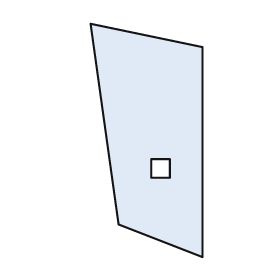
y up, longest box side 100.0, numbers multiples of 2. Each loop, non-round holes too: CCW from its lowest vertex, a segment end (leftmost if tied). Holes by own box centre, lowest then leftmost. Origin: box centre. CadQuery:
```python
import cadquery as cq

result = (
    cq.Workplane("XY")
    .moveTo(24.0, -50.0)
    .lineTo(24.0, 40.0)
    .lineTo(-24.0, 50.0)
    .lineTo(-12.0, -36.0)
    .close()
    .moveTo(2.0, -16.0)
    .lineTo(10.0, -16.0)
    .lineTo(10.0, -8.0)
    .lineTo(2.0, -8.0)
    .close()
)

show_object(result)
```